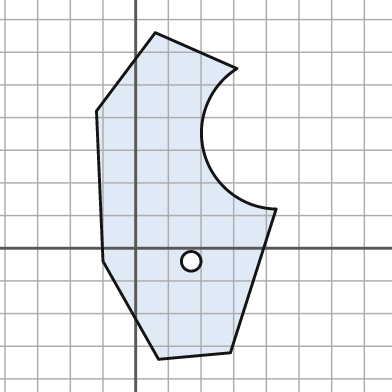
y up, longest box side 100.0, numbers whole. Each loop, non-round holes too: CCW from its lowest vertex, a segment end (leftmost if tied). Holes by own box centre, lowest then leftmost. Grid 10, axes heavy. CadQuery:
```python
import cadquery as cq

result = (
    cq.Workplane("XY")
    .moveTo(7.0, -34.0)
    .lineTo(29.0, -32.0)
    .lineTo(43.0, 12.0)
    .threePointArc((21.0, 29.0), (31.0, 55.0))
    .lineTo(6.0, 66.0)
    .lineTo(-12.0, 42.0)
    .lineTo(-10.0, -4.0)
    .close()
    .moveTo(17.0, -4.0)
    .circle(3.0)
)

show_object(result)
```